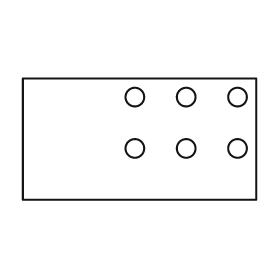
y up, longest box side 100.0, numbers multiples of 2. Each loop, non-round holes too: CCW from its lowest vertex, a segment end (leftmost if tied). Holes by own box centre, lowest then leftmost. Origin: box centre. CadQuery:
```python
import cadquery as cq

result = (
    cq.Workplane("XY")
    .moveTo(-50.0, -26.0)
    .lineTo(50.0, -26.0)
    .lineTo(50.0, 26.0)
    .lineTo(-50.0, 26.0)
    .close()
    .moveTo(-2.0, -4.0)
    .circle(4.0)
    .moveTo(20.0, -4.0)
    .circle(4.0)
    .moveTo(42.0, -4.0)
    .circle(4.0)
    .moveTo(-2.0, 18.0)
    .circle(4.0)
    .moveTo(20.0, 18.0)
    .circle(4.0)
    .moveTo(42.0, 18.0)
    .circle(4.0)
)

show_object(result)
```